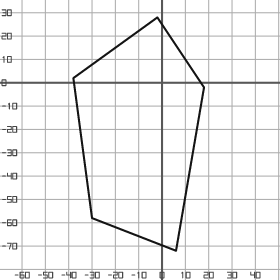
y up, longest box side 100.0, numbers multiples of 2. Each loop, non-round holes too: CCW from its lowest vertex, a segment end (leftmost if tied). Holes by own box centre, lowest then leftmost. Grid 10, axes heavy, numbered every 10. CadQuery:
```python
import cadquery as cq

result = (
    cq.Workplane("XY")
    .moveTo(6.0, -72.0)
    .lineTo(18.0, -2.0)
    .lineTo(-2.0, 28.0)
    .lineTo(-38.0, 2.0)
    .lineTo(-30.0, -58.0)
    .close()
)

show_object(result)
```